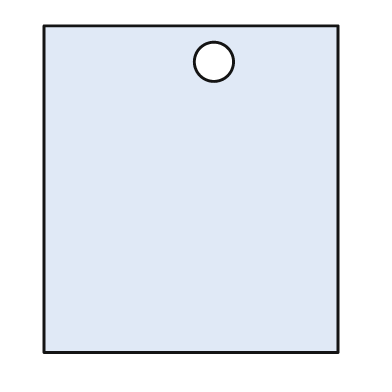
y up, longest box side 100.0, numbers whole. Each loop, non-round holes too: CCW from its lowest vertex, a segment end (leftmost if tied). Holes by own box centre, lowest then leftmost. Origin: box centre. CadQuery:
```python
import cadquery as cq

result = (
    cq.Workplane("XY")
    .moveTo(-45.0, -50.0)
    .lineTo(45.0, -50.0)
    .lineTo(45.0, 50.0)
    .lineTo(-45.0, 50.0)
    .close()
    .moveTo(7.0, 39.0)
    .circle(6.0)
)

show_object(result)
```